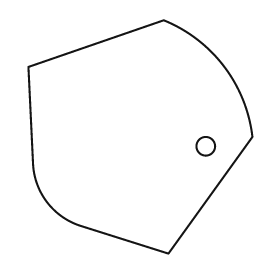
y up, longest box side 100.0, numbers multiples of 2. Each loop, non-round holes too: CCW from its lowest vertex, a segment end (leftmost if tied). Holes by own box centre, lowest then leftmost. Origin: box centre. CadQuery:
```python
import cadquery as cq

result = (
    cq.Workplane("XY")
    .moveTo(12.0, -50.0)
    .lineTo(48.0, 0.0)
    .threePointArc((36.0, 30.0), (10.0, 50.0))
    .lineTo(-48.0, 30.0)
    .lineTo(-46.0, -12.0)
    .threePointArc((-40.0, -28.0), (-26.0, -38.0))
    .close()
    .moveTo(28.0, -4.0)
    .circle(4.0)
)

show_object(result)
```